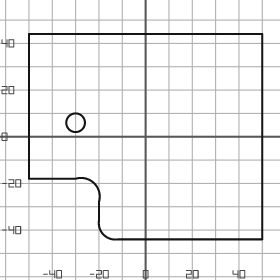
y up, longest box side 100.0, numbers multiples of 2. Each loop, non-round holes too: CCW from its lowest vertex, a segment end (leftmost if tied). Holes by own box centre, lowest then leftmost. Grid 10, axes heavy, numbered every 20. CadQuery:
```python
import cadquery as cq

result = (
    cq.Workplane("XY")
    .moveTo(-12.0, -44.0)
    .lineTo(50.0, -44.0)
    .lineTo(50.0, 44.0)
    .lineTo(-50.0, 44.0)
    .lineTo(-50.0, -18.0)
    .lineTo(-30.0, -18.0)
    .threePointArc((-22.0, -20.0), (-20.0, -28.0))
    .lineTo(-20.0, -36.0)
    .threePointArc((-18.0, -42.0), (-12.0, -44.0))
    .close()
    .moveTo(-30.0, 6.0)
    .circle(4.0)
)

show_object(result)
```